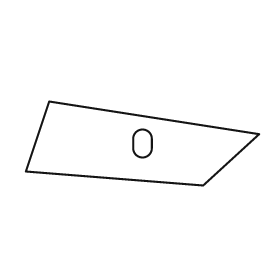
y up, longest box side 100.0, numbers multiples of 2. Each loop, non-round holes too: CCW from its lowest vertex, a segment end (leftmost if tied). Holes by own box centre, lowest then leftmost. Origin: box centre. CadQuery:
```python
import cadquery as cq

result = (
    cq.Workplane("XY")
    .moveTo(26.0, -18.0)
    .lineTo(50.0, 4.0)
    .lineTo(-40.0, 18.0)
    .lineTo(-50.0, -12.0)
    .close()
    .moveTo(-4.0, -2.0)
    .threePointArc((0.0, -6.0), (4.0, -2.0))
    .lineTo(4.0, 2.0)
    .threePointArc((0.0, 6.0), (-4.0, 2.0))
    .close()
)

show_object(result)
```